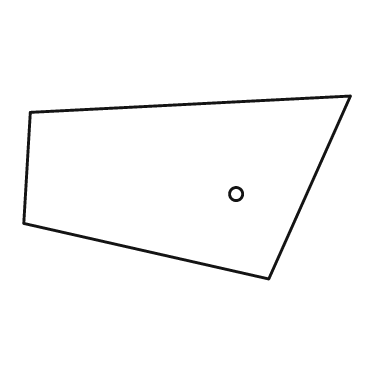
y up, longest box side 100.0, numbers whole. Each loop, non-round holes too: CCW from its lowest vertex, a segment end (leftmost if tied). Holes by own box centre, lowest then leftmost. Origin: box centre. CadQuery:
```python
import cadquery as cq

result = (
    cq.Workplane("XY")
    .moveTo(25.0, -28.0)
    .lineTo(50.0, 28.0)
    .lineTo(-48.0, 23.0)
    .lineTo(-50.0, -11.0)
    .close()
    .moveTo(15.0, -2.0)
    .circle(2.0)
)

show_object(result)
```